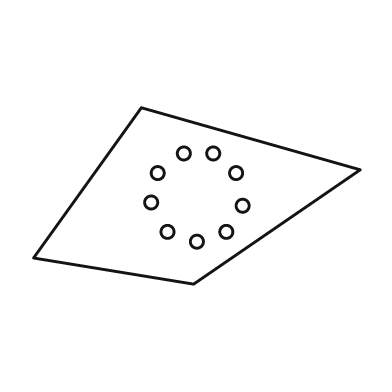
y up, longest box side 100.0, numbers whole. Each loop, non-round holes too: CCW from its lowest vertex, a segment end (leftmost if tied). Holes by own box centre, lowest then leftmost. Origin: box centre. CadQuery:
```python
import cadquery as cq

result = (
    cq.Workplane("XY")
    .moveTo(-1.0, -27.0)
    .lineTo(50.0, 8.0)
    .lineTo(-17.0, 27.0)
    .lineTo(-50.0, -19.0)
    .close()
    .moveTo(0.0, -14.0)
    .circle(2.0)
    .moveTo(-9.0, -11.0)
    .circle(2.0)
    .moveTo(9.0, -11.0)
    .circle(2.0)
    .moveTo(14.0, -3.0)
    .circle(2.0)
    .moveTo(-14.0, -2.0)
    .circle(2.0)
    .moveTo(-12.0, 7.0)
    .circle(2.0)
    .moveTo(12.0, 7.0)
    .circle(2.0)
    .moveTo(-4.0, 13.0)
    .circle(2.0)
    .moveTo(5.0, 13.0)
    .circle(2.0)
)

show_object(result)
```